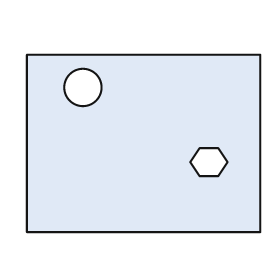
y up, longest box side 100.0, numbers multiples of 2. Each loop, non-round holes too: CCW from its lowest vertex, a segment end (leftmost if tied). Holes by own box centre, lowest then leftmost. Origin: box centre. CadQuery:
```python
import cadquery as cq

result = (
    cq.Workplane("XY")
    .moveTo(-50.0, -38.0)
    .lineTo(50.0, -38.0)
    .lineTo(50.0, 38.0)
    .lineTo(-50.0, 38.0)
    .close()
    .moveTo(24.0, -14.0)
    .lineTo(32.0, -14.0)
    .lineTo(36.0, -8.0)
    .lineTo(32.0, -2.0)
    .lineTo(24.0, -2.0)
    .lineTo(20.0, -8.0)
    .close()
    .moveTo(-26.0, 24.0)
    .circle(8.0)
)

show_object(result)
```